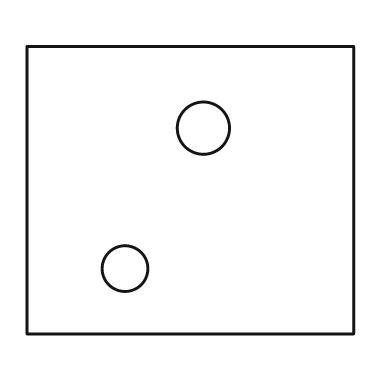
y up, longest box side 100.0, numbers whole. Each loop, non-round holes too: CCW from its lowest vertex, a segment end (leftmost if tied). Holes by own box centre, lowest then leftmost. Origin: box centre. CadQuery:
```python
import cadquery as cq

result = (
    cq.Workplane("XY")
    .moveTo(-50.0, -44.0)
    .lineTo(50.0, -44.0)
    .lineTo(50.0, 44.0)
    .lineTo(-50.0, 44.0)
    .close()
    .moveTo(-20.0, -24.0)
    .circle(7.0)
    .moveTo(4.0, 19.0)
    .circle(8.0)
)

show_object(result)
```